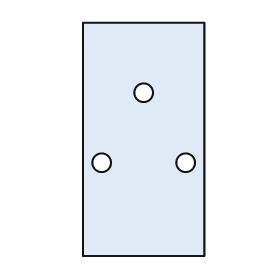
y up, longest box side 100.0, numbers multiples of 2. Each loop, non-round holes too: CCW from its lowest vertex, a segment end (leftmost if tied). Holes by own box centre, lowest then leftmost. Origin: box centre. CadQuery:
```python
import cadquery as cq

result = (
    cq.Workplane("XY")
    .moveTo(-26.0, -50.0)
    .lineTo(26.0, -50.0)
    .lineTo(26.0, 50.0)
    .lineTo(-26.0, 50.0)
    .close()
    .moveTo(-18.0, -10.0)
    .circle(4.0)
    .moveTo(18.0, -10.0)
    .circle(4.0)
    .moveTo(0.0, 20.0)
    .circle(4.0)
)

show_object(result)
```